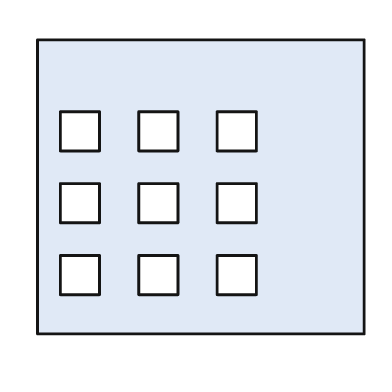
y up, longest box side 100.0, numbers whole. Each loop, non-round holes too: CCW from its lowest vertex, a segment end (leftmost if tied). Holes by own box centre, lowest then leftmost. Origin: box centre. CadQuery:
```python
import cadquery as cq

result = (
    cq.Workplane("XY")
    .moveTo(-50.0, -45.0)
    .lineTo(50.0, -45.0)
    .lineTo(50.0, 45.0)
    .lineTo(-50.0, 45.0)
    .close()
    .moveTo(-43.0, -33.0)
    .lineTo(-31.0, -33.0)
    .lineTo(-31.0, -21.0)
    .lineTo(-43.0, -21.0)
    .close()
    .moveTo(-19.0, -33.0)
    .lineTo(-7.0, -33.0)
    .lineTo(-7.0, -21.0)
    .lineTo(-19.0, -21.0)
    .close()
    .moveTo(5.0, -33.0)
    .lineTo(17.0, -33.0)
    .lineTo(17.0, -21.0)
    .lineTo(5.0, -21.0)
    .close()
    .moveTo(-43.0, -11.0)
    .lineTo(-31.0, -11.0)
    .lineTo(-31.0, 1.0)
    .lineTo(-43.0, 1.0)
    .close()
    .moveTo(-19.0, -11.0)
    .lineTo(-7.0, -11.0)
    .lineTo(-7.0, 1.0)
    .lineTo(-19.0, 1.0)
    .close()
    .moveTo(5.0, -11.0)
    .lineTo(17.0, -11.0)
    .lineTo(17.0, 1.0)
    .lineTo(5.0, 1.0)
    .close()
    .moveTo(-43.0, 11.0)
    .lineTo(-31.0, 11.0)
    .lineTo(-31.0, 23.0)
    .lineTo(-43.0, 23.0)
    .close()
    .moveTo(-19.0, 11.0)
    .lineTo(-7.0, 11.0)
    .lineTo(-7.0, 23.0)
    .lineTo(-19.0, 23.0)
    .close()
    .moveTo(5.0, 11.0)
    .lineTo(17.0, 11.0)
    .lineTo(17.0, 23.0)
    .lineTo(5.0, 23.0)
    .close()
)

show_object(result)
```